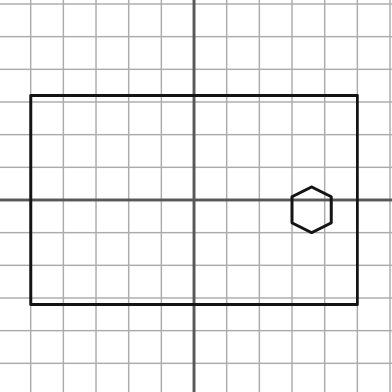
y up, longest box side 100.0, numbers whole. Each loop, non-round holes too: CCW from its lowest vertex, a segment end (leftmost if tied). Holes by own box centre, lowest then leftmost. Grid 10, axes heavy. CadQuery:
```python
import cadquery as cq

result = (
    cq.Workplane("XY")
    .moveTo(-50.0, -32.0)
    .lineTo(50.0, -32.0)
    .lineTo(50.0, 32.0)
    .lineTo(-50.0, 32.0)
    .close()
    .moveTo(36.0, -10.0)
    .lineTo(42.0, -7.0)
    .lineTo(42.0, 1.0)
    .lineTo(36.0, 4.0)
    .lineTo(30.0, 1.0)
    .lineTo(30.0, -7.0)
    .close()
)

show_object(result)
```